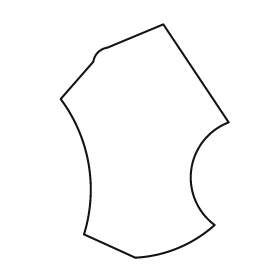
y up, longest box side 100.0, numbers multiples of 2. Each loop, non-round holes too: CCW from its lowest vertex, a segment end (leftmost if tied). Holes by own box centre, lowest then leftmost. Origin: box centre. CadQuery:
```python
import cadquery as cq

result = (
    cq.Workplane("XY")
    .moveTo(-4.0, -50.0)
    .threePointArc((14.0, -46.0), (30.0, -36.0))
    .threePointArc((20.0, -12.0), (36.0, 8.0))
    .lineTo(8.0, 50.0)
    .lineTo(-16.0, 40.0)
    .threePointArc((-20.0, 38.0), (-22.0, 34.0))
    .lineTo(-36.0, 18.0)
    .threePointArc((-24.0, -10.0), (-26.0, -40.0))
    .close()
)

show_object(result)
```